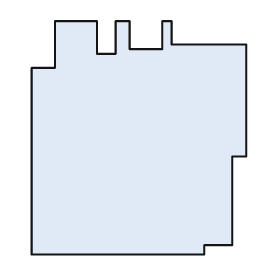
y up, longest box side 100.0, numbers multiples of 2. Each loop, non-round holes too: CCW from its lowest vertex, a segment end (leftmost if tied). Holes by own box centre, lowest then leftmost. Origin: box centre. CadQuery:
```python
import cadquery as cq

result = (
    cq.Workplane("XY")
    .moveTo(-46.0, -50.0)
    .lineTo(28.0, -50.0)
    .lineTo(28.0, -46.0)
    .lineTo(40.0, -46.0)
    .lineTo(40.0, -8.0)
    .lineTo(46.0, -8.0)
    .lineTo(46.0, 40.0)
    .lineTo(14.0, 40.0)
    .lineTo(14.0, 50.0)
    .lineTo(10.0, 50.0)
    .lineTo(10.0, 38.0)
    .lineTo(-4.0, 38.0)
    .lineTo(-4.0, 50.0)
    .lineTo(-10.0, 50.0)
    .lineTo(-10.0, 36.0)
    .lineTo(-18.0, 36.0)
    .lineTo(-18.0, 50.0)
    .lineTo(-36.0, 50.0)
    .lineTo(-36.0, 30.0)
    .lineTo(-46.0, 30.0)
    .close()
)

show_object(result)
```